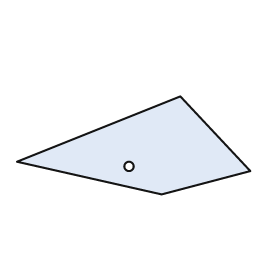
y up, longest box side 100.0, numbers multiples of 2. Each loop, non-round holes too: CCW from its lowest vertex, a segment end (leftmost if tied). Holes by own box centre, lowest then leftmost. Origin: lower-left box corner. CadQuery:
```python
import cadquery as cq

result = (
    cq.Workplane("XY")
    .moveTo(62.0, 0.0)
    .lineTo(100.0, 10.0)
    .lineTo(70.0, 42.0)
    .lineTo(0.0, 14.0)
    .close()
    .moveTo(48.0, 12.0)
    .circle(2.0)
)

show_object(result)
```